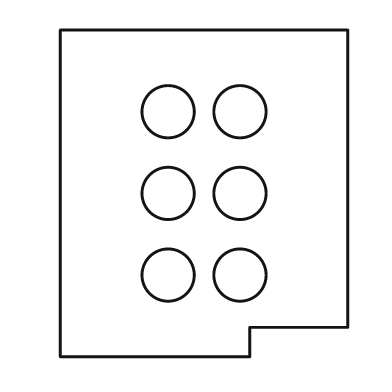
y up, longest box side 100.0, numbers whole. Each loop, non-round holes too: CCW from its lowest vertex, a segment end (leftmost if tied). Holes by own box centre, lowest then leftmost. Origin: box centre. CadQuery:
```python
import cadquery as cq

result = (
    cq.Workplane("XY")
    .moveTo(-44.0, -50.0)
    .lineTo(14.0, -50.0)
    .lineTo(14.0, -41.0)
    .lineTo(44.0, -41.0)
    .lineTo(44.0, 50.0)
    .lineTo(-44.0, 50.0)
    .close()
    .moveTo(-11.0, -25.0)
    .circle(8.0)
    .moveTo(11.0, -25.0)
    .circle(8.0)
    .moveTo(-11.0, 0.0)
    .circle(8.0)
    .moveTo(11.0, 0.0)
    .circle(8.0)
    .moveTo(-11.0, 25.0)
    .circle(8.0)
    .moveTo(11.0, 25.0)
    .circle(8.0)
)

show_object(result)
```